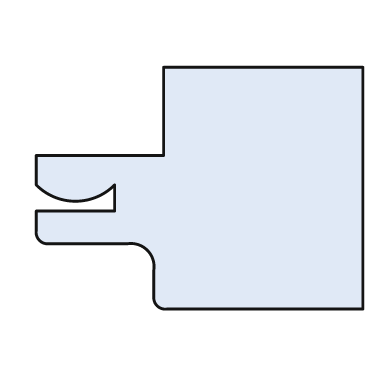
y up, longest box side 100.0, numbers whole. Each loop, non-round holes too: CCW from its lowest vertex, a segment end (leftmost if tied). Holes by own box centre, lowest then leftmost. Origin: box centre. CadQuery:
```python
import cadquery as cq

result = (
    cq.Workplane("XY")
    .moveTo(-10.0, -37.0)
    .lineTo(50.0, -37.0)
    .lineTo(50.0, 37.0)
    .lineTo(-11.0, 37.0)
    .lineTo(-11.0, 10.0)
    .lineTo(-50.0, 10.0)
    .lineTo(-50.0, 1.0)
    .threePointArc((-38.0, -4.0), (-26.0, 1.0))
    .lineTo(-26.0, -7.0)
    .lineTo(-50.0, -7.0)
    .lineTo(-50.0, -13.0)
    .threePointArc((-49.0, -16.0), (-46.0, -17.0))
    .lineTo(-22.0, -17.0)
    .threePointArc((-16.0, -19.0), (-14.0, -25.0))
    .lineTo(-14.0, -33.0)
    .threePointArc((-13.0, -36.0), (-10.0, -37.0))
    .close()
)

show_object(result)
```